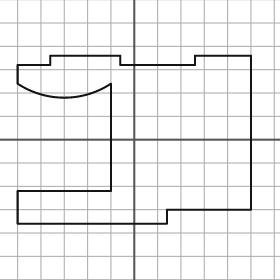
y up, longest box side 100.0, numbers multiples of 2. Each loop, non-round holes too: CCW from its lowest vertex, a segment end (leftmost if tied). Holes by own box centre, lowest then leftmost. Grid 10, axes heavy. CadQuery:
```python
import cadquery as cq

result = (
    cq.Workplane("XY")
    .moveTo(-50.0, -36.0)
    .lineTo(14.0, -36.0)
    .lineTo(14.0, -30.0)
    .lineTo(50.0, -30.0)
    .lineTo(50.0, 36.0)
    .lineTo(26.0, 36.0)
    .lineTo(26.0, 32.0)
    .lineTo(-6.0, 32.0)
    .lineTo(-6.0, 36.0)
    .lineTo(-36.0, 36.0)
    .lineTo(-36.0, 32.0)
    .lineTo(-50.0, 32.0)
    .lineTo(-50.0, 24.0)
    .threePointArc((-30.0, 18.0), (-10.0, 24.0))
    .lineTo(-10.0, -22.0)
    .lineTo(-50.0, -22.0)
    .close()
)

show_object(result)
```